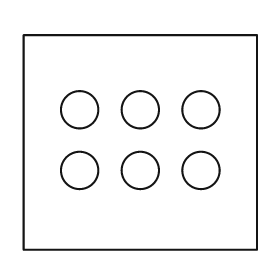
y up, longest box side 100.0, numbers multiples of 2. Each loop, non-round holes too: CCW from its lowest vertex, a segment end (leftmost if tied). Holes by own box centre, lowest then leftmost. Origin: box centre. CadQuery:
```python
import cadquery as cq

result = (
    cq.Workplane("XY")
    .moveTo(-50.0, -46.0)
    .lineTo(50.0, -46.0)
    .lineTo(50.0, 46.0)
    .lineTo(-50.0, 46.0)
    .close()
    .moveTo(-26.0, -12.0)
    .circle(8.0)
    .moveTo(0.0, -12.0)
    .circle(8.0)
    .moveTo(26.0, -12.0)
    .circle(8.0)
    .moveTo(-26.0, 14.0)
    .circle(8.0)
    .moveTo(0.0, 14.0)
    .circle(8.0)
    .moveTo(26.0, 14.0)
    .circle(8.0)
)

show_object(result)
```